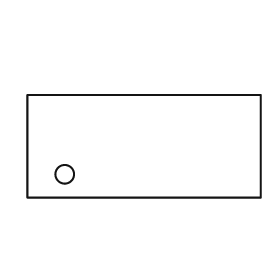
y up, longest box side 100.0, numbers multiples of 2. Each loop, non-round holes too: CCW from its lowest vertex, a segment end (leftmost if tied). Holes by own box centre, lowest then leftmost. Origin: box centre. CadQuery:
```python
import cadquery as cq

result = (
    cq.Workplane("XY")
    .moveTo(-50.0, -22.0)
    .lineTo(50.0, -22.0)
    .lineTo(50.0, 22.0)
    .lineTo(-50.0, 22.0)
    .close()
    .moveTo(-34.0, -12.0)
    .circle(4.0)
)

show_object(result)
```